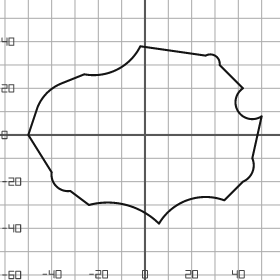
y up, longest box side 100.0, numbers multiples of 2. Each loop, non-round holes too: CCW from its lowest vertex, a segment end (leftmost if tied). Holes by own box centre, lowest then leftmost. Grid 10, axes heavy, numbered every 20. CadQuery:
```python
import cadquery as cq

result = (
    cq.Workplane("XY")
    .moveTo(6.0, -38.0)
    .threePointArc((18.0, -28.0), (34.0, -28.0))
    .lineTo(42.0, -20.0)
    .threePointArc((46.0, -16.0), (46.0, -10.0))
    .lineTo(50.0, 8.0)
    .threePointArc((40.0, 10.0), (42.0, 20.0))
    .lineTo(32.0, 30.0)
    .threePointArc((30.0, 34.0), (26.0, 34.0))
    .lineTo(-2.0, 38.0)
    .threePointArc((-12.0, 28.0), (-26.0, 26.0))
    .lineTo(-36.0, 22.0)
    .threePointArc((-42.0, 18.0), (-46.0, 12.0))
    .lineTo(-50.0, 0.0)
    .lineTo(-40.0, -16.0)
    .threePointArc((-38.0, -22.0), (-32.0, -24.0))
    .lineTo(-24.0, -30.0)
    .threePointArc((-8.0, -30.0), (6.0, -38.0))
    .close()
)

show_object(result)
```